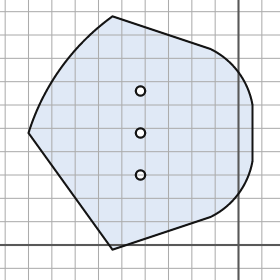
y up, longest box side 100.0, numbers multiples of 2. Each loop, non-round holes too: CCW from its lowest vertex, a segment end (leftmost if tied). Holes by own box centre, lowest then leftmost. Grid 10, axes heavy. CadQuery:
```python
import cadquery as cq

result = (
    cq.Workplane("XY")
    .moveTo(-54.0, -2.0)
    .lineTo(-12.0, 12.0)
    .threePointArc((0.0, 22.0), (6.0, 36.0))
    .lineTo(6.0, 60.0)
    .threePointArc((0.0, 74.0), (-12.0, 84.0))
    .lineTo(-54.0, 98.0)
    .threePointArc((-76.0, 76.0), (-90.0, 48.0))
    .close()
    .moveTo(-42.0, 30.0)
    .circle(2.0)
    .moveTo(-42.0, 48.0)
    .circle(2.0)
    .moveTo(-42.0, 66.0)
    .circle(2.0)
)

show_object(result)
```